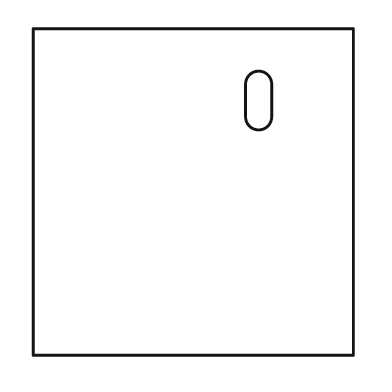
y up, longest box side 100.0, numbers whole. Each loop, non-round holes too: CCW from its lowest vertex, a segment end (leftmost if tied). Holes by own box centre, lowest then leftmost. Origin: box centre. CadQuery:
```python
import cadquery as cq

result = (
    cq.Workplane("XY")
    .moveTo(-49.0, -50.0)
    .lineTo(49.0, -50.0)
    .lineTo(49.0, 50.0)
    .lineTo(-49.0, 50.0)
    .close()
    .moveTo(16.0, 23.0)
    .threePointArc((20.0, 19.0), (24.0, 23.0))
    .lineTo(24.0, 33.0)
    .threePointArc((20.0, 37.0), (16.0, 33.0))
    .close()
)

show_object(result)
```